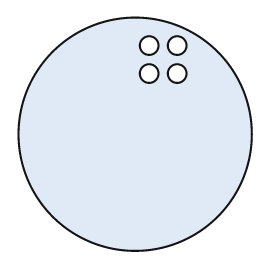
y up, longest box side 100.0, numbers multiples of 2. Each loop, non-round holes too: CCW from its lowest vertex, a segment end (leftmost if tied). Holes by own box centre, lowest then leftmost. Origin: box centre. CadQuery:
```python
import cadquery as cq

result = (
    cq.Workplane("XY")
    .moveTo(0.0, 0.0)
    .circle(50.0)
    .moveTo(6.0, 26.0)
    .circle(4.0)
    .moveTo(18.0, 26.0)
    .circle(4.0)
    .moveTo(6.0, 38.0)
    .circle(4.0)
    .moveTo(18.0, 38.0)
    .circle(4.0)
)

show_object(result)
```